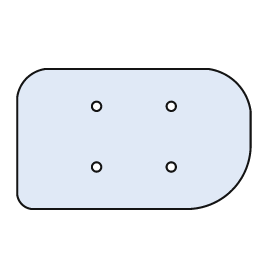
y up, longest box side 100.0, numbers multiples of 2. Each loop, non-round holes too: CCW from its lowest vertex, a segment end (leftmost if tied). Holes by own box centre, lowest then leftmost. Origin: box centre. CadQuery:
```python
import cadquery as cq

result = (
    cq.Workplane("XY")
    .moveTo(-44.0, -30.0)
    .lineTo(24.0, -30.0)
    .threePointArc((42.0, -22.0), (50.0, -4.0))
    .lineTo(50.0, 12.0)
    .threePointArc((44.0, 24.0), (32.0, 30.0))
    .lineTo(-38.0, 30.0)
    .threePointArc((-46.0, 26.0), (-50.0, 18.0))
    .lineTo(-50.0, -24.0)
    .threePointArc((-48.0, -28.0), (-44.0, -30.0))
    .close()
    .moveTo(-16.0, -12.0)
    .circle(2.0)
    .moveTo(16.0, -12.0)
    .circle(2.0)
    .moveTo(-16.0, 14.0)
    .circle(2.0)
    .moveTo(16.0, 14.0)
    .circle(2.0)
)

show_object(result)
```